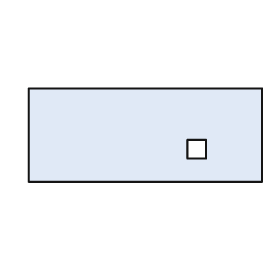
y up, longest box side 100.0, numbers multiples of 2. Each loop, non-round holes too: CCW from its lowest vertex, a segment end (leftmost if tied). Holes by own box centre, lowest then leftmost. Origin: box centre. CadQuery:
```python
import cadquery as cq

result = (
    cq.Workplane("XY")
    .moveTo(-50.0, -20.0)
    .lineTo(50.0, -20.0)
    .lineTo(50.0, 20.0)
    .lineTo(-50.0, 20.0)
    .close()
    .moveTo(18.0, -10.0)
    .lineTo(26.0, -10.0)
    .lineTo(26.0, -2.0)
    .lineTo(18.0, -2.0)
    .close()
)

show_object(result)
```